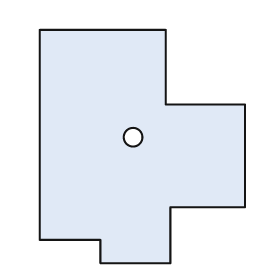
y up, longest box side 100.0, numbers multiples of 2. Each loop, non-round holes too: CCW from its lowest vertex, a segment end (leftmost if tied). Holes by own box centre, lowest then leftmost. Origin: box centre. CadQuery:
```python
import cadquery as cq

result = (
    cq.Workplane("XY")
    .moveTo(-18.0, -50.0)
    .lineTo(12.0, -50.0)
    .lineTo(12.0, -26.0)
    .lineTo(44.0, -26.0)
    .lineTo(44.0, 18.0)
    .lineTo(10.0, 18.0)
    .lineTo(10.0, 50.0)
    .lineTo(-44.0, 50.0)
    .lineTo(-44.0, -40.0)
    .lineTo(-18.0, -40.0)
    .close()
    .moveTo(-4.0, 4.0)
    .circle(4.0)
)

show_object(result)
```